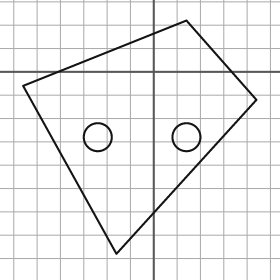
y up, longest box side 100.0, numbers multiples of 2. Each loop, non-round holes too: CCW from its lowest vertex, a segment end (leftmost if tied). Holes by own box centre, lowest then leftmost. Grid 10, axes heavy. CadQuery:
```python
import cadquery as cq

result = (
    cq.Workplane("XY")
    .moveTo(-16.0, -78.0)
    .lineTo(44.0, -12.0)
    .lineTo(14.0, 22.0)
    .lineTo(-56.0, -6.0)
    .close()
    .moveTo(-24.0, -28.0)
    .circle(6.0)
    .moveTo(14.0, -28.0)
    .circle(6.0)
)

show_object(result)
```